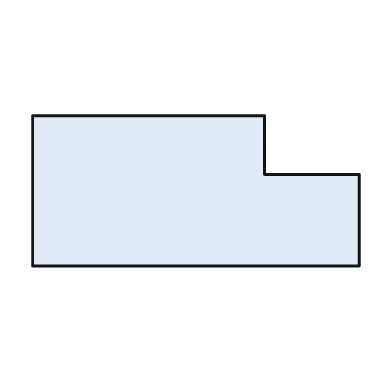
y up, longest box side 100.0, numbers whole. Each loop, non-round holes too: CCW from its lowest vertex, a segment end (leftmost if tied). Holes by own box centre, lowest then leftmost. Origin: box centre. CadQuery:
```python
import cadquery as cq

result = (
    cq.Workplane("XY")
    .moveTo(-50.0, -23.0)
    .lineTo(50.0, -23.0)
    .lineTo(50.0, 5.0)
    .lineTo(21.0, 5.0)
    .lineTo(21.0, 23.0)
    .lineTo(-50.0, 23.0)
    .close()
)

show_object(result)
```